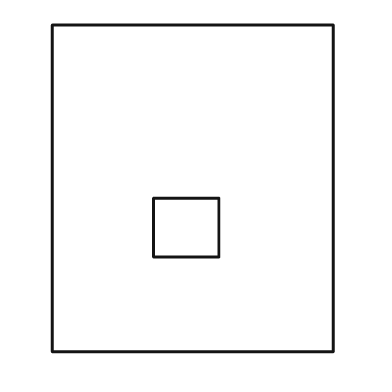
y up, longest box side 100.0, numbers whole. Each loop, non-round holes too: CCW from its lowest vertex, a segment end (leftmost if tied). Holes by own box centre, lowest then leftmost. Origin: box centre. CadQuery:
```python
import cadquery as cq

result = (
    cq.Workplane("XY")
    .moveTo(-43.0, -50.0)
    .lineTo(43.0, -50.0)
    .lineTo(43.0, 50.0)
    .lineTo(-43.0, 50.0)
    .close()
    .moveTo(-12.0, -21.0)
    .lineTo(8.0, -21.0)
    .lineTo(8.0, -3.0)
    .lineTo(-12.0, -3.0)
    .close()
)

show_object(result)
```